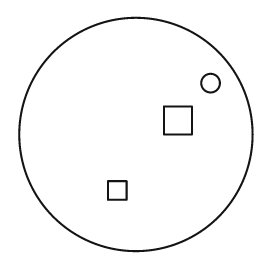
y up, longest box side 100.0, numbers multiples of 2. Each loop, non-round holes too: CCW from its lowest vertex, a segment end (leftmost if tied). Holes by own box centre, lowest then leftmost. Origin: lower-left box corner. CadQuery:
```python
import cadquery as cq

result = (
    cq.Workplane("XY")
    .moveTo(50.0, 50.0)
    .circle(50.0)
    .moveTo(38.0, 22.0)
    .lineTo(46.0, 22.0)
    .lineTo(46.0, 30.0)
    .lineTo(38.0, 30.0)
    .close()
    .moveTo(62.0, 50.0)
    .lineTo(74.0, 50.0)
    .lineTo(74.0, 62.0)
    .lineTo(62.0, 62.0)
    .close()
    .moveTo(82.0, 72.0)
    .circle(4.0)
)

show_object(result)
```